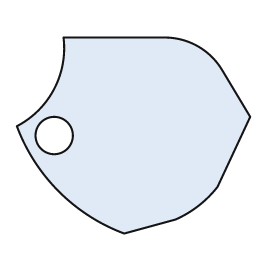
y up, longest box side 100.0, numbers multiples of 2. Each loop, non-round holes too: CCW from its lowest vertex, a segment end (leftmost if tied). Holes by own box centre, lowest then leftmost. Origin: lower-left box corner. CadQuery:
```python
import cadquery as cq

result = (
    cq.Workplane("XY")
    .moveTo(46.0, 0.0)
    .lineTo(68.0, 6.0)
    .threePointArc((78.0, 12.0), (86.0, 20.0))
    .lineTo(100.0, 50.0)
    .lineTo(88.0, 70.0)
    .threePointArc((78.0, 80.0), (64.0, 84.0))
    .lineTo(20.0, 84.0)
    .threePointArc((16.0, 62.0), (0.0, 46.0))
    .threePointArc((18.0, 18.0), (46.0, 0.0))
    .close()
    .moveTo(16.0, 42.0)
    .circle(8.0)
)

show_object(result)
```